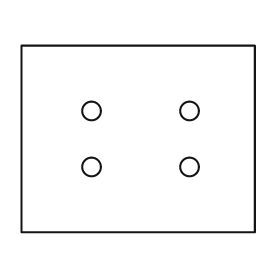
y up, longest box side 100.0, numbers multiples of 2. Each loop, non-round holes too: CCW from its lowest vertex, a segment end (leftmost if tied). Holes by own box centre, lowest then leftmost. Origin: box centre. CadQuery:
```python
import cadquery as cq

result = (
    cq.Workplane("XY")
    .moveTo(-50.0, -40.0)
    .lineTo(50.0, -40.0)
    .lineTo(50.0, 40.0)
    .lineTo(-50.0, 40.0)
    .close()
    .moveTo(-20.0, -12.0)
    .circle(4.0)
    .moveTo(22.0, -12.0)
    .circle(4.0)
    .moveTo(-20.0, 12.0)
    .circle(4.0)
    .moveTo(22.0, 12.0)
    .circle(4.0)
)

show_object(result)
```